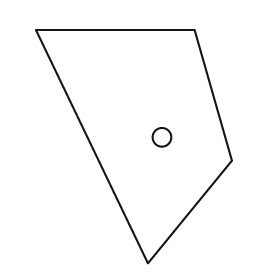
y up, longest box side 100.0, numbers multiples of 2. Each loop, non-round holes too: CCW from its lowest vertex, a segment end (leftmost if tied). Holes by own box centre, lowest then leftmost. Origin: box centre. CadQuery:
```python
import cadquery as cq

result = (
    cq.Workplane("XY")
    .moveTo(6.0, -50.0)
    .lineTo(42.0, -6.0)
    .lineTo(26.0, 50.0)
    .lineTo(-42.0, 50.0)
    .close()
    .moveTo(12.0, 4.0)
    .circle(4.0)
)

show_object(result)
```